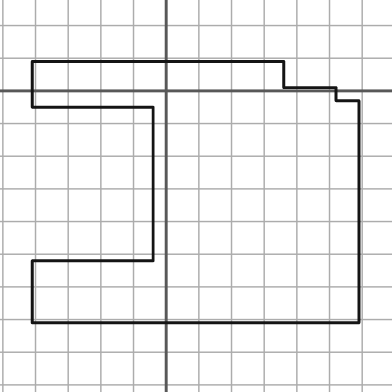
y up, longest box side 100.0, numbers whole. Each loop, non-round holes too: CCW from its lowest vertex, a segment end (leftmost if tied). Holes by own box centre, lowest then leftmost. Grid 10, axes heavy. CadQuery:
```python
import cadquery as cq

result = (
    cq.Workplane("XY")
    .moveTo(-41.0, -71.0)
    .lineTo(59.0, -71.0)
    .lineTo(59.0, -3.0)
    .lineTo(52.0, -3.0)
    .lineTo(52.0, 1.0)
    .lineTo(36.0, 1.0)
    .lineTo(36.0, 9.0)
    .lineTo(-41.0, 9.0)
    .lineTo(-41.0, -5.0)
    .lineTo(-4.0, -5.0)
    .lineTo(-4.0, -52.0)
    .lineTo(-41.0, -52.0)
    .close()
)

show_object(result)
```